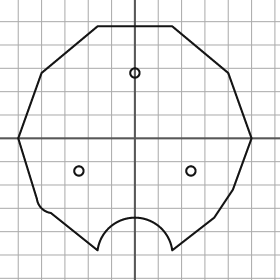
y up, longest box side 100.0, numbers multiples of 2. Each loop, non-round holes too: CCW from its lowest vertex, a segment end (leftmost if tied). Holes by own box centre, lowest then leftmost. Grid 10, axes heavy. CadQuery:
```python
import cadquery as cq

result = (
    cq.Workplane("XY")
    .moveTo(-16.0, -48.0)
    .threePointArc((0.0, -34.0), (16.0, -48.0))
    .lineTo(34.0, -34.0)
    .lineTo(42.0, -22.0)
    .lineTo(50.0, 0.0)
    .lineTo(40.0, 28.0)
    .lineTo(16.0, 48.0)
    .lineTo(-16.0, 48.0)
    .lineTo(-40.0, 28.0)
    .lineTo(-50.0, 0.0)
    .lineTo(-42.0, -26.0)
    .threePointArc((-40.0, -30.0), (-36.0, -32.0))
    .close()
    .moveTo(-24.0, -14.0)
    .circle(2.0)
    .moveTo(24.0, -14.0)
    .circle(2.0)
    .moveTo(0.0, 28.0)
    .circle(2.0)
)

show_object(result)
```